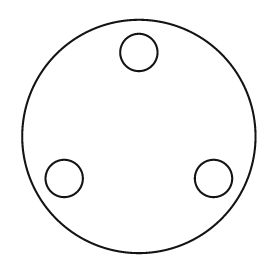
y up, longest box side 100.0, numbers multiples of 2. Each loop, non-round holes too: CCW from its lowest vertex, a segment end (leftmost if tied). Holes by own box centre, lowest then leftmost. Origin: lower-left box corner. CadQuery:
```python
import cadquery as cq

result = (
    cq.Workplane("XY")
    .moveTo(50.0, 50.0)
    .circle(50.0)
    .moveTo(18.0, 32.0)
    .circle(8.0)
    .moveTo(82.0, 32.0)
    .circle(8.0)
    .moveTo(50.0, 86.0)
    .circle(8.0)
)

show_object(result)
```